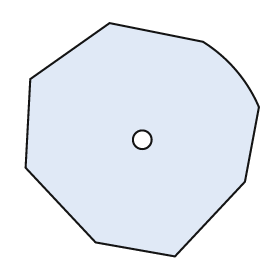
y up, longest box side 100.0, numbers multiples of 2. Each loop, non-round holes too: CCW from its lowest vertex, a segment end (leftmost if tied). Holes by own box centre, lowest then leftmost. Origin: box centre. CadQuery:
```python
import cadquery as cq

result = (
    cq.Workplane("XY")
    .moveTo(14.0, -50.0)
    .lineTo(44.0, -18.0)
    .lineTo(50.0, 14.0)
    .threePointArc((40.0, 30.0), (26.0, 42.0))
    .lineTo(-14.0, 50.0)
    .lineTo(-48.0, 26.0)
    .lineTo(-50.0, -12.0)
    .lineTo(-20.0, -44.0)
    .close()
    .moveTo(0.0, 0.0)
    .circle(4.0)
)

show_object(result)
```